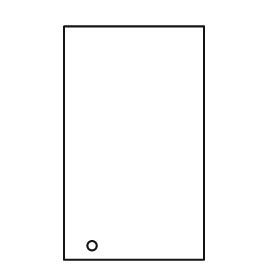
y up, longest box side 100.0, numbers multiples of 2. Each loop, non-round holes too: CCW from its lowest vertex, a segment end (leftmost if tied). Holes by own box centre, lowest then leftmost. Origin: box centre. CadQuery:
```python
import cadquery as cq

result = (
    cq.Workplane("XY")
    .moveTo(-30.0, -50.0)
    .lineTo(30.0, -50.0)
    .lineTo(30.0, 50.0)
    .lineTo(-30.0, 50.0)
    .close()
    .moveTo(-18.0, -44.0)
    .circle(2.0)
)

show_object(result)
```